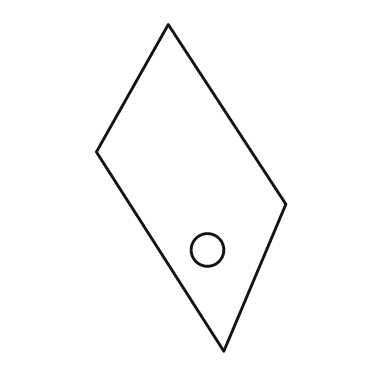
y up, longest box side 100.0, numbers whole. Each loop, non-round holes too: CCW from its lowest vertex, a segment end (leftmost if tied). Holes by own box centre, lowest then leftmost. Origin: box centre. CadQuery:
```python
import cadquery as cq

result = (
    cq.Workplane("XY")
    .moveTo(10.0, -50.0)
    .lineTo(29.0, -5.0)
    .lineTo(-7.0, 50.0)
    .lineTo(-29.0, 11.0)
    .close()
    .moveTo(5.0, -19.0)
    .circle(5.0)
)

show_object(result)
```